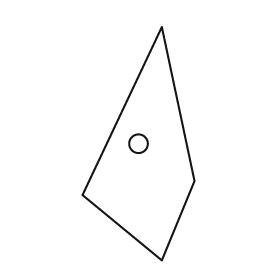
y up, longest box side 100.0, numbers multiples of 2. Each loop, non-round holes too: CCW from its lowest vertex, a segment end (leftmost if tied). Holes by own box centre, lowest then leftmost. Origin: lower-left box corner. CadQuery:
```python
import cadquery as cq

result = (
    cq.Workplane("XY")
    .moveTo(34.0, 0.0)
    .lineTo(48.0, 34.0)
    .lineTo(34.0, 100.0)
    .lineTo(0.0, 28.0)
    .close()
    .moveTo(24.0, 50.0)
    .circle(4.0)
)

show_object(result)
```